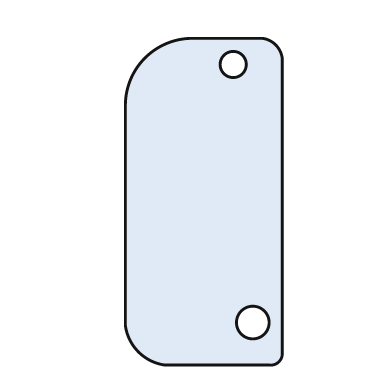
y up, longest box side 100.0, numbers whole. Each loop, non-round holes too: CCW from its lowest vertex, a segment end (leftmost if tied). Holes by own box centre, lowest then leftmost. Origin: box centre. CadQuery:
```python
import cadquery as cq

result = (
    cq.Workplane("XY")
    .moveTo(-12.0, -50.0)
    .lineTo(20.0, -50.0)
    .threePointArc((23.0, -49.0), (24.0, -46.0))
    .lineTo(24.0, 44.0)
    .threePointArc((22.0, 48.0), (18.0, 50.0))
    .lineTo(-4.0, 50.0)
    .threePointArc((-18.0, 44.0), (-24.0, 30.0))
    .lineTo(-24.0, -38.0)
    .threePointArc((-20.0, -46.0), (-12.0, -50.0))
    .close()
    .moveTo(15.0, -37.0)
    .circle(5.0)
    .moveTo(9.0, 42.0)
    .circle(4.0)
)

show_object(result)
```